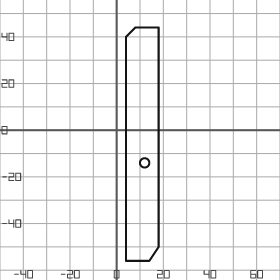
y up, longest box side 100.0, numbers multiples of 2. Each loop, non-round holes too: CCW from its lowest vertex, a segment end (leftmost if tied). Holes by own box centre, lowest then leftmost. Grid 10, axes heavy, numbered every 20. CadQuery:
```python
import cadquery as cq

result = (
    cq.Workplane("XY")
    .moveTo(4.0, -56.0)
    .lineTo(14.0, -56.0)
    .lineTo(18.0, -50.0)
    .lineTo(18.0, 44.0)
    .lineTo(8.0, 44.0)
    .lineTo(4.0, 40.0)
    .close()
    .moveTo(12.0, -14.0)
    .circle(2.0)
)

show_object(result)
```